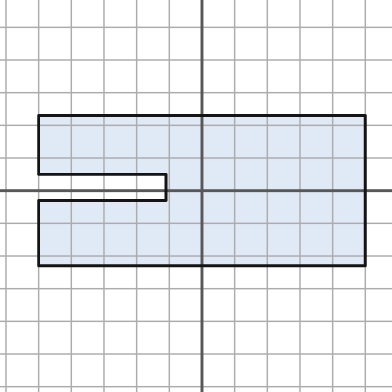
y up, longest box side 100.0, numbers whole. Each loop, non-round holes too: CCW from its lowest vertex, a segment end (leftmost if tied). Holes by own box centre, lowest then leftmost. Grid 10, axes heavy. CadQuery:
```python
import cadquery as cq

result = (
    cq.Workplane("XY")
    .moveTo(-50.0, -23.0)
    .lineTo(50.0, -23.0)
    .lineTo(50.0, 23.0)
    .lineTo(-50.0, 23.0)
    .lineTo(-50.0, 5.0)
    .lineTo(-11.0, 5.0)
    .lineTo(-11.0, -3.0)
    .lineTo(-50.0, -3.0)
    .close()
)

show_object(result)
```